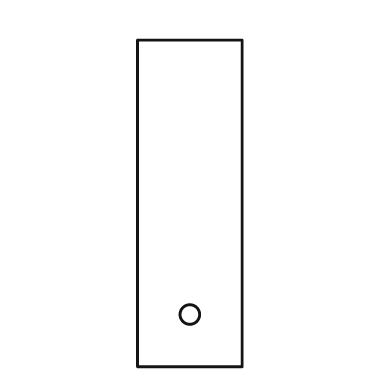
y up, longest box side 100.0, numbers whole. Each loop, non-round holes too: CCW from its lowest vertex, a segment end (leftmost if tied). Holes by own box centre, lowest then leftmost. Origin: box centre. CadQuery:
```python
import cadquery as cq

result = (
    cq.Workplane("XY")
    .moveTo(-16.0, -50.0)
    .lineTo(16.0, -50.0)
    .lineTo(16.0, 50.0)
    .lineTo(-16.0, 50.0)
    .close()
    .moveTo(0.0, -34.0)
    .circle(3.0)
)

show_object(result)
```